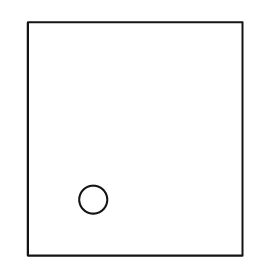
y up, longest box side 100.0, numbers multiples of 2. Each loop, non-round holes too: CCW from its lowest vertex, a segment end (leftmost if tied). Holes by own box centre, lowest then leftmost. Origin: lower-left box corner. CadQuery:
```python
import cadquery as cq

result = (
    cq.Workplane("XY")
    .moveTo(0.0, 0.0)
    .lineTo(92.0, 0.0)
    .lineTo(92.0, 100.0)
    .lineTo(0.0, 100.0)
    .close()
    .moveTo(28.0, 24.0)
    .circle(6.0)
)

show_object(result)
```